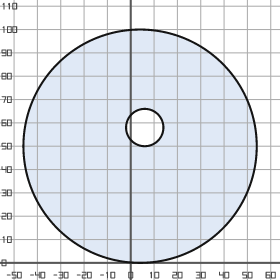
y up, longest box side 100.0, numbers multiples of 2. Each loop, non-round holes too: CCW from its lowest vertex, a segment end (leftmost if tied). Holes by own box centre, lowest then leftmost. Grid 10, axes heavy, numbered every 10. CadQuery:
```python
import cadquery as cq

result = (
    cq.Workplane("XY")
    .moveTo(4.0, 50.0)
    .circle(50.0)
    .moveTo(6.0, 58.0)
    .circle(8.0)
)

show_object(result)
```